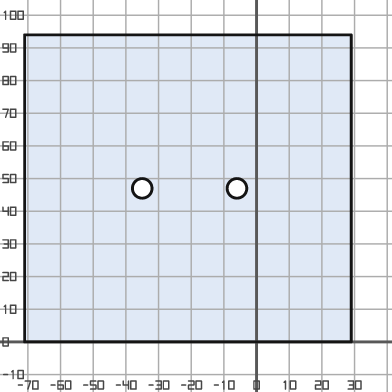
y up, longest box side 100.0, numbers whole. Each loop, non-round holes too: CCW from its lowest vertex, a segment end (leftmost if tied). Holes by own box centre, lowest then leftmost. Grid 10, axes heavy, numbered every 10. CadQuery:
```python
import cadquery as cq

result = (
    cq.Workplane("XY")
    .moveTo(-71.0, 0.0)
    .lineTo(29.0, 0.0)
    .lineTo(29.0, 94.0)
    .lineTo(-71.0, 94.0)
    .close()
    .moveTo(-35.0, 47.0)
    .circle(3.0)
    .moveTo(-6.0, 47.0)
    .circle(3.0)
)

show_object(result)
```